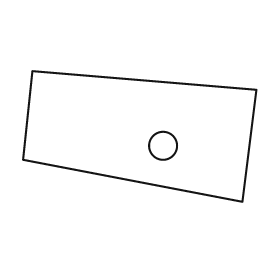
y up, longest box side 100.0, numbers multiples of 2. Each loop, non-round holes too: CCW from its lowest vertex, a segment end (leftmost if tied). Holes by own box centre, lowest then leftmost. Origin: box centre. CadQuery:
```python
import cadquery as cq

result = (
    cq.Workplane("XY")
    .moveTo(44.0, -28.0)
    .lineTo(50.0, 20.0)
    .lineTo(-46.0, 28.0)
    .lineTo(-50.0, -10.0)
    .close()
    .moveTo(10.0, -4.0)
    .circle(6.0)
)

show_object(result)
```